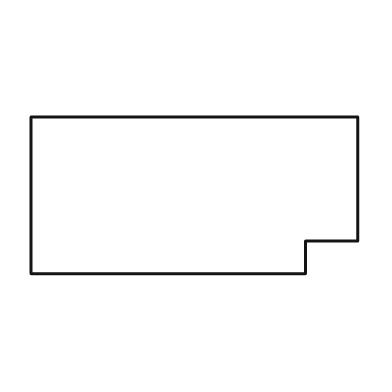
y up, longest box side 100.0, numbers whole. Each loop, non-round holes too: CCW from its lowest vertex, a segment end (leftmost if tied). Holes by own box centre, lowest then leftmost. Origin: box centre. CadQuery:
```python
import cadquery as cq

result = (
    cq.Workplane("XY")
    .moveTo(-50.0, -24.0)
    .lineTo(34.0, -24.0)
    .lineTo(34.0, -14.0)
    .lineTo(50.0, -14.0)
    .lineTo(50.0, 24.0)
    .lineTo(-50.0, 24.0)
    .close()
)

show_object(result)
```